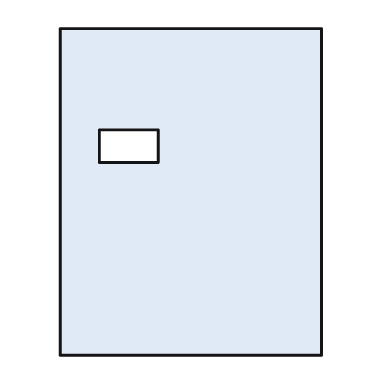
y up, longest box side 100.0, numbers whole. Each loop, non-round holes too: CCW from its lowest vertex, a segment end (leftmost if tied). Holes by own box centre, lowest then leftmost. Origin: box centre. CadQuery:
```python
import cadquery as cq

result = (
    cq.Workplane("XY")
    .moveTo(-40.0, -50.0)
    .lineTo(40.0, -50.0)
    .lineTo(40.0, 50.0)
    .lineTo(-40.0, 50.0)
    .close()
    .moveTo(-28.0, 9.0)
    .lineTo(-10.0, 9.0)
    .lineTo(-10.0, 19.0)
    .lineTo(-28.0, 19.0)
    .close()
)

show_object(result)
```